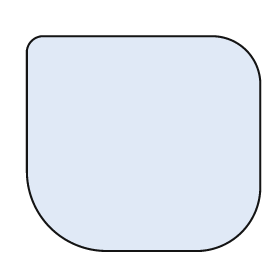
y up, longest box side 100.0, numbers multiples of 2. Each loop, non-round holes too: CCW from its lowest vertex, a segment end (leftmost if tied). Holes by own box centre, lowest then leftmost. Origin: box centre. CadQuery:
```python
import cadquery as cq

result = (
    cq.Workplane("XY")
    .moveTo(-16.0, -46.0)
    .lineTo(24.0, -46.0)
    .threePointArc((42.0, -38.0), (50.0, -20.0))
    .lineTo(50.0, 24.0)
    .threePointArc((44.0, 40.0), (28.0, 46.0))
    .lineTo(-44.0, 46.0)
    .threePointArc((-48.0, 44.0), (-50.0, 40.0))
    .lineTo(-50.0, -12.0)
    .threePointArc((-40.0, -36.0), (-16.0, -46.0))
    .close()
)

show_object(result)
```